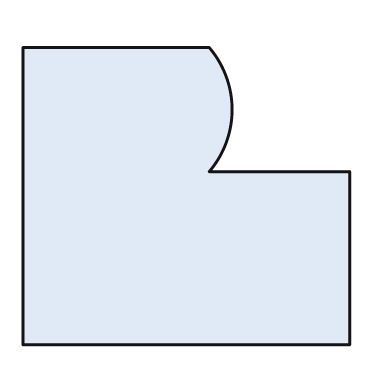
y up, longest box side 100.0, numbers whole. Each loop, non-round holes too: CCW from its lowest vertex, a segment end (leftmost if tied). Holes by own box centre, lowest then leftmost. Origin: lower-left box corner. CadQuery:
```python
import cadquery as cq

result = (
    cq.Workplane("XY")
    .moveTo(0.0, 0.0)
    .lineTo(100.0, 0.0)
    .lineTo(100.0, 53.0)
    .lineTo(57.0, 53.0)
    .threePointArc((64.0, 72.0), (57.0, 91.0))
    .lineTo(0.0, 91.0)
    .close()
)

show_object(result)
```